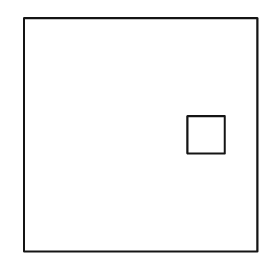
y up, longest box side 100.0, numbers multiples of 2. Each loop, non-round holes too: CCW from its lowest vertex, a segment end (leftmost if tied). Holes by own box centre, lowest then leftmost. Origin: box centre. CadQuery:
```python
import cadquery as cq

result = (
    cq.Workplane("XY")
    .moveTo(-50.0, -50.0)
    .lineTo(50.0, -50.0)
    .lineTo(50.0, 50.0)
    .lineTo(-50.0, 50.0)
    .close()
    .moveTo(20.0, -8.0)
    .lineTo(36.0, -8.0)
    .lineTo(36.0, 8.0)
    .lineTo(20.0, 8.0)
    .close()
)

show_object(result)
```